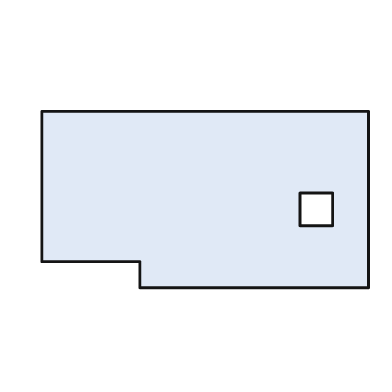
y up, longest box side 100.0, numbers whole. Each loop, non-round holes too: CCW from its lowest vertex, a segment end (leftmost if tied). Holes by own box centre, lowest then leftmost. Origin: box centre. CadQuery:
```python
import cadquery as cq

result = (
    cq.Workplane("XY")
    .moveTo(-20.0, -27.0)
    .lineTo(50.0, -27.0)
    .lineTo(50.0, 27.0)
    .lineTo(-50.0, 27.0)
    .lineTo(-50.0, -19.0)
    .lineTo(-20.0, -19.0)
    .close()
    .moveTo(29.0, -8.0)
    .lineTo(39.0, -8.0)
    .lineTo(39.0, 2.0)
    .lineTo(29.0, 2.0)
    .close()
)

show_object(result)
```